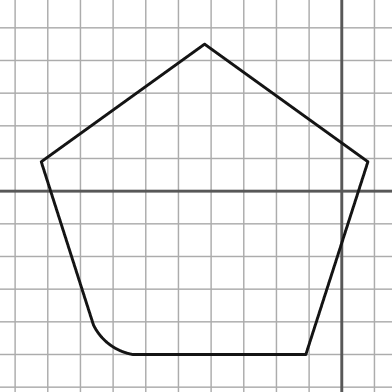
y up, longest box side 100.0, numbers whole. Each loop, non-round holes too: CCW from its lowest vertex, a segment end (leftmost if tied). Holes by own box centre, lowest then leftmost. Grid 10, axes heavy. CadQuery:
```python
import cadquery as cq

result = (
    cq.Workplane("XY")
    .moveTo(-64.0, -50.0)
    .lineTo(-11.0, -50.0)
    .lineTo(8.0, 9.0)
    .lineTo(-42.0, 45.0)
    .lineTo(-92.0, 9.0)
    .lineTo(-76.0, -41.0)
    .threePointArc((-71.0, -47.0), (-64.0, -50.0))
    .close()
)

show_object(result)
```